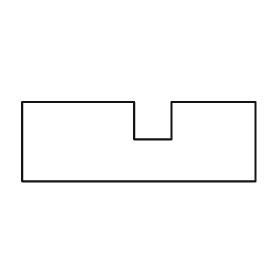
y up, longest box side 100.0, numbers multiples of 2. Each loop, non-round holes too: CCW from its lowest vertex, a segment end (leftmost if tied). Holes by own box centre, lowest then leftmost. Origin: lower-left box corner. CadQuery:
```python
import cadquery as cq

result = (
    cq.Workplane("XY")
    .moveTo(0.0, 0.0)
    .lineTo(100.0, 0.0)
    .lineTo(100.0, 34.0)
    .lineTo(64.0, 34.0)
    .lineTo(64.0, 18.0)
    .lineTo(48.0, 18.0)
    .lineTo(48.0, 34.0)
    .lineTo(0.0, 34.0)
    .close()
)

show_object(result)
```